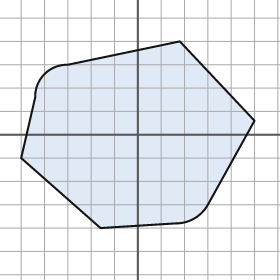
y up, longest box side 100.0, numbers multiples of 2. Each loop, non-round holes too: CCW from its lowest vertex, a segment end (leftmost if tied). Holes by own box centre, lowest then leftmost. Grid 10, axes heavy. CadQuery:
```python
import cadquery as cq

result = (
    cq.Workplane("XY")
    .moveTo(-16.0, -40.0)
    .lineTo(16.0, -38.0)
    .threePointArc((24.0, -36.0), (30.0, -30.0))
    .lineTo(50.0, 6.0)
    .lineTo(18.0, 40.0)
    .lineTo(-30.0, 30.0)
    .threePointArc((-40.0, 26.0), (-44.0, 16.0))
    .lineTo(-50.0, -10.0)
    .close()
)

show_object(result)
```